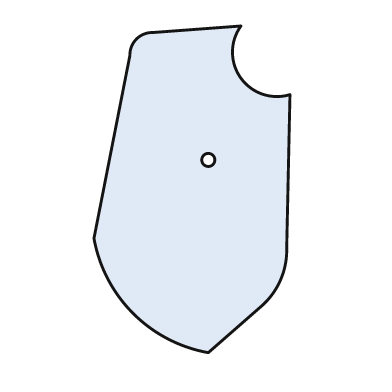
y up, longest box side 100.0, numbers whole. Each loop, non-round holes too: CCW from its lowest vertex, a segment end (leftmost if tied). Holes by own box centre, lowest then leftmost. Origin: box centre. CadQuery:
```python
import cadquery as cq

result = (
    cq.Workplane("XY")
    .moveTo(5.0, -50.0)
    .lineTo(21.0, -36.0)
    .threePointArc((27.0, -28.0), (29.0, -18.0))
    .lineTo(30.0, 29.0)
    .threePointArc((15.0, 34.0), (15.0, 50.0))
    .lineTo(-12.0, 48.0)
    .threePointArc((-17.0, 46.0), (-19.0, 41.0))
    .lineTo(-30.0, -15.0)
    .threePointArc((-18.0, -38.0), (5.0, -50.0))
    .close()
    .moveTo(5.0, 9.0)
    .circle(2.0)
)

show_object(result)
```